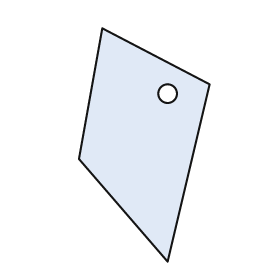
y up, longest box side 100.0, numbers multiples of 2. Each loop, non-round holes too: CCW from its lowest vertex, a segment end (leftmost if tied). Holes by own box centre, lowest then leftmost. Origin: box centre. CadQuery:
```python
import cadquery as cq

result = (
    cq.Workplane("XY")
    .moveTo(10.0, -50.0)
    .lineTo(28.0, 26.0)
    .lineTo(-18.0, 50.0)
    .lineTo(-28.0, -6.0)
    .close()
    .moveTo(10.0, 22.0)
    .circle(4.0)
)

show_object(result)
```